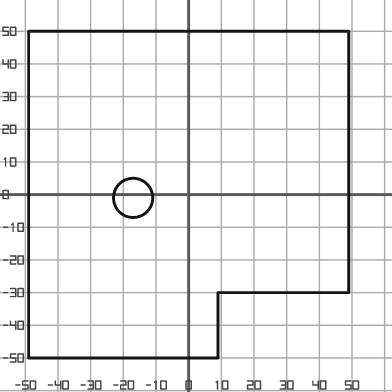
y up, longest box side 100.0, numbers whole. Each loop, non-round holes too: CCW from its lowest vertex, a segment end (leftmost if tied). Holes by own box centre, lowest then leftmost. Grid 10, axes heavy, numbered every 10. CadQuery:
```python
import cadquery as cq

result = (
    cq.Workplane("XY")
    .moveTo(-49.0, -50.0)
    .lineTo(9.0, -50.0)
    .lineTo(9.0, -30.0)
    .lineTo(49.0, -30.0)
    .lineTo(49.0, 50.0)
    .lineTo(-49.0, 50.0)
    .close()
    .moveTo(-17.0, -1.0)
    .circle(6.0)
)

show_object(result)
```